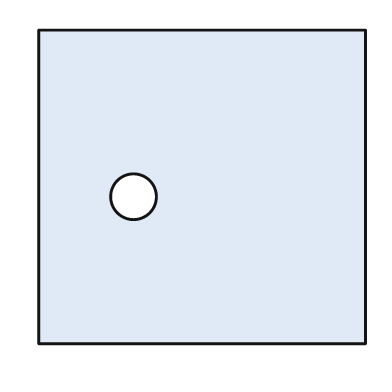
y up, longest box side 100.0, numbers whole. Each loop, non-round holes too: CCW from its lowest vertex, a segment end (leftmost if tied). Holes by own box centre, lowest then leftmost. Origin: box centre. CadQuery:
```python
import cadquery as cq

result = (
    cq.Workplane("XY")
    .moveTo(-50.0, -48.0)
    .lineTo(50.0, -48.0)
    .lineTo(50.0, 48.0)
    .lineTo(-50.0, 48.0)
    .close()
    .moveTo(-21.0, -3.0)
    .circle(7.0)
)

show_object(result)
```